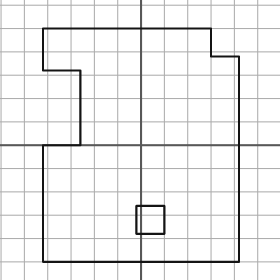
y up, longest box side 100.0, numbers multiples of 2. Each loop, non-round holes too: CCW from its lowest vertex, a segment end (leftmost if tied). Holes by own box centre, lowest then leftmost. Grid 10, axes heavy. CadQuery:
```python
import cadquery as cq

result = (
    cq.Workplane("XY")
    .moveTo(-42.0, -50.0)
    .lineTo(42.0, -50.0)
    .lineTo(42.0, 38.0)
    .lineTo(30.0, 38.0)
    .lineTo(30.0, 50.0)
    .lineTo(-42.0, 50.0)
    .lineTo(-42.0, 32.0)
    .lineTo(-26.0, 32.0)
    .lineTo(-26.0, 0.0)
    .lineTo(-42.0, 0.0)
    .close()
    .moveTo(-2.0, -38.0)
    .lineTo(10.0, -38.0)
    .lineTo(10.0, -26.0)
    .lineTo(-2.0, -26.0)
    .close()
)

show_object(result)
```